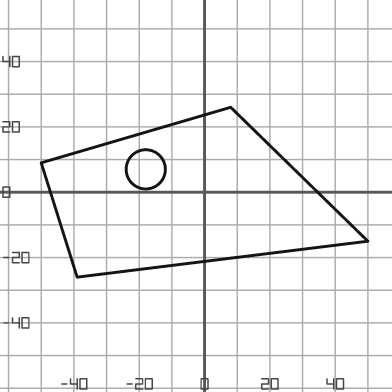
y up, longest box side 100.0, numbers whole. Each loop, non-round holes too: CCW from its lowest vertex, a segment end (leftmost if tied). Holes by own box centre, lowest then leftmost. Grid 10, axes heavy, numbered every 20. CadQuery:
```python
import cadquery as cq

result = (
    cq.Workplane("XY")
    .moveTo(-39.0, -26.0)
    .lineTo(50.0, -15.0)
    .lineTo(8.0, 26.0)
    .lineTo(-50.0, 9.0)
    .close()
    .moveTo(-18.0, 7.0)
    .circle(6.0)
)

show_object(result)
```